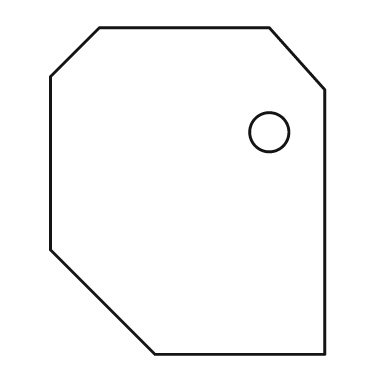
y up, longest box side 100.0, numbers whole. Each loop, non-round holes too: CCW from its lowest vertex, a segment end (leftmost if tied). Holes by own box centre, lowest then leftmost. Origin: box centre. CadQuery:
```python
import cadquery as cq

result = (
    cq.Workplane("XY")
    .moveTo(-10.0, -50.0)
    .lineTo(42.0, -50.0)
    .lineTo(42.0, 31.0)
    .lineTo(25.0, 50.0)
    .lineTo(-27.0, 50.0)
    .lineTo(-42.0, 35.0)
    .lineTo(-42.0, -18.0)
    .close()
    .moveTo(25.0, 18.0)
    .circle(6.0)
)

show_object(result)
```